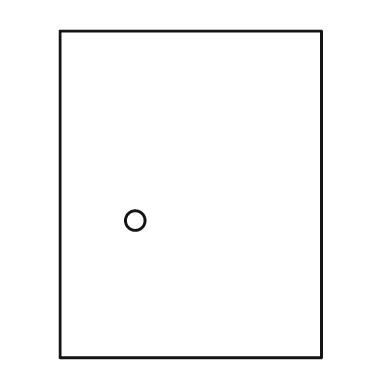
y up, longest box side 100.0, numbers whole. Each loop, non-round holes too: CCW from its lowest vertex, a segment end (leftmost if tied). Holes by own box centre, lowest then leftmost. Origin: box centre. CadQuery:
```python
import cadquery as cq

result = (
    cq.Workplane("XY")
    .moveTo(-40.0, -50.0)
    .lineTo(40.0, -50.0)
    .lineTo(40.0, 50.0)
    .lineTo(-40.0, 50.0)
    .close()
    .moveTo(-17.0, -8.0)
    .circle(3.0)
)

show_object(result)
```